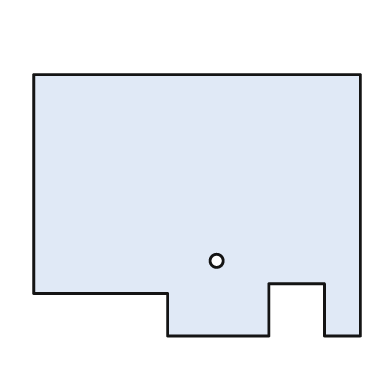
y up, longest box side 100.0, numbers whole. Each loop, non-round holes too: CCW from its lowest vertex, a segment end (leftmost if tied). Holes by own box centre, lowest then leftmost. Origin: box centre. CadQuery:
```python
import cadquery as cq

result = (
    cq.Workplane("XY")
    .moveTo(-9.0, -40.0)
    .lineTo(22.0, -40.0)
    .lineTo(22.0, -24.0)
    .lineTo(39.0, -24.0)
    .lineTo(39.0, -40.0)
    .lineTo(50.0, -40.0)
    .lineTo(50.0, 40.0)
    .lineTo(-50.0, 40.0)
    .lineTo(-50.0, -27.0)
    .lineTo(-9.0, -27.0)
    .close()
    .moveTo(6.0, -17.0)
    .circle(2.0)
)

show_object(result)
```